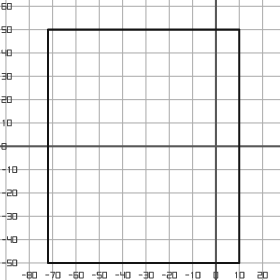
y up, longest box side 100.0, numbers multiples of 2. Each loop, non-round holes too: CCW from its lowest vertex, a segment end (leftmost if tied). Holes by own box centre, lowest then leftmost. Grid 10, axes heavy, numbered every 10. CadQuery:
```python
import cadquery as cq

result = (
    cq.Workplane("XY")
    .moveTo(-72.0, -50.0)
    .lineTo(10.0, -50.0)
    .lineTo(10.0, 50.0)
    .lineTo(-72.0, 50.0)
    .close()
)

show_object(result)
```